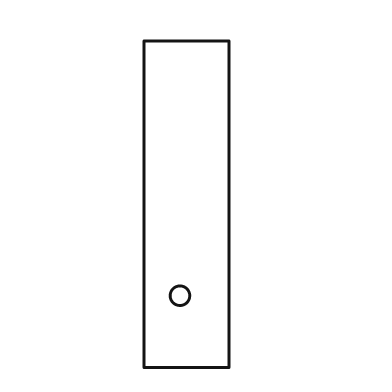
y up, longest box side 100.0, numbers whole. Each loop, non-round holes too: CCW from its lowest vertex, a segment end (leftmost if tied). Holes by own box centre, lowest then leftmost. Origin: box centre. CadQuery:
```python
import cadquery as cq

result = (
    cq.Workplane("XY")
    .moveTo(-13.0, -50.0)
    .lineTo(13.0, -50.0)
    .lineTo(13.0, 50.0)
    .lineTo(-13.0, 50.0)
    .close()
    .moveTo(-2.0, -28.0)
    .circle(3.0)
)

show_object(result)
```